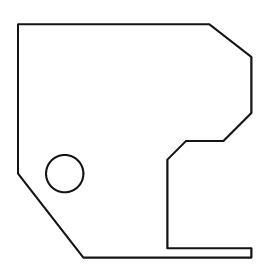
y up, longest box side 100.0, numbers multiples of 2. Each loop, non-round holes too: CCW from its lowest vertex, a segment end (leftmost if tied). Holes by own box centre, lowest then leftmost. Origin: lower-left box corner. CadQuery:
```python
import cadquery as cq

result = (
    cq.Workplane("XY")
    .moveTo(28.0, 0.0)
    .lineTo(100.0, 0.0)
    .lineTo(100.0, 4.0)
    .lineTo(64.0, 4.0)
    .lineTo(64.0, 42.0)
    .lineTo(72.0, 50.0)
    .lineTo(88.0, 50.0)
    .lineTo(100.0, 62.0)
    .lineTo(100.0, 86.0)
    .lineTo(82.0, 100.0)
    .lineTo(0.0, 100.0)
    .lineTo(0.0, 36.0)
    .close()
    .moveTo(20.0, 36.0)
    .circle(8.0)
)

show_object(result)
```